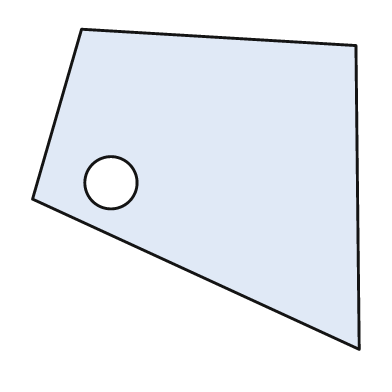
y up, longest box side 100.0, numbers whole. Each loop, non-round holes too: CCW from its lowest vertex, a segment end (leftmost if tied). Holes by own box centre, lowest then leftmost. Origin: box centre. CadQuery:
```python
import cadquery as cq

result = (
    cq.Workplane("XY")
    .moveTo(50.0, -49.0)
    .lineTo(49.0, 44.0)
    .lineTo(-35.0, 49.0)
    .lineTo(-50.0, -3.0)
    .close()
    .moveTo(-26.0, 2.0)
    .circle(8.0)
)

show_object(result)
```